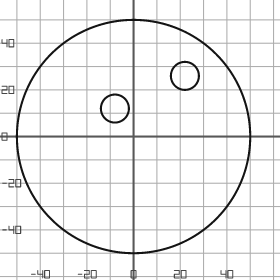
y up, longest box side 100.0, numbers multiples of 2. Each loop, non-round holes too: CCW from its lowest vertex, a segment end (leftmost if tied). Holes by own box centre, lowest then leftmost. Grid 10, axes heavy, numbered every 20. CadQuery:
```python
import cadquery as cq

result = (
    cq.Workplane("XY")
    .moveTo(0.0, 0.0)
    .circle(50.0)
    .moveTo(-8.0, 12.0)
    .circle(6.0)
    .moveTo(22.0, 26.0)
    .circle(6.0)
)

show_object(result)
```